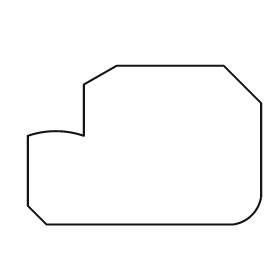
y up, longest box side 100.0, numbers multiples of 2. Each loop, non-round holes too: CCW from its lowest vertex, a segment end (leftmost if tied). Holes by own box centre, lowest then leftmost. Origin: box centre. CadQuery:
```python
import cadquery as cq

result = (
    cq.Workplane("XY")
    .moveTo(-42.0, -34.0)
    .lineTo(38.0, -34.0)
    .threePointArc((46.0, -30.0), (50.0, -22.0))
    .lineTo(50.0, 18.0)
    .lineTo(34.0, 34.0)
    .lineTo(-12.0, 34.0)
    .lineTo(-26.0, 26.0)
    .lineTo(-26.0, 4.0)
    .threePointArc((-38.0, 6.0), (-50.0, 4.0))
    .lineTo(-50.0, -26.0)
    .close()
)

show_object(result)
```